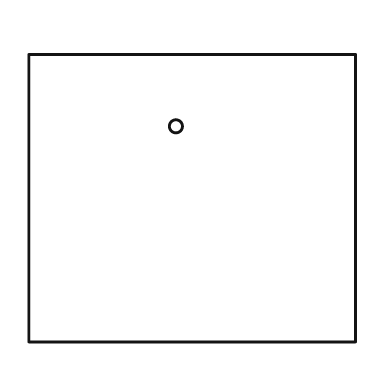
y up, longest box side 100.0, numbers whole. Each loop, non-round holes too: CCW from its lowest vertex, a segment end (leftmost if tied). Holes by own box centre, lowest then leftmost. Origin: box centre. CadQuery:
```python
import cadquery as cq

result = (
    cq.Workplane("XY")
    .moveTo(-50.0, -44.0)
    .lineTo(50.0, -44.0)
    .lineTo(50.0, 44.0)
    .lineTo(-50.0, 44.0)
    .close()
    .moveTo(-5.0, 22.0)
    .circle(2.0)
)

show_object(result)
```